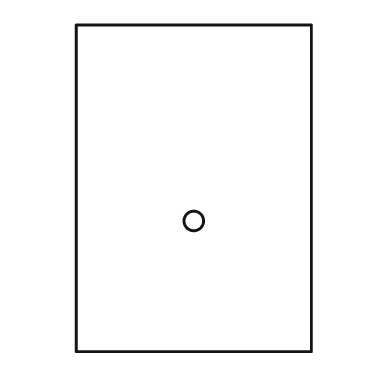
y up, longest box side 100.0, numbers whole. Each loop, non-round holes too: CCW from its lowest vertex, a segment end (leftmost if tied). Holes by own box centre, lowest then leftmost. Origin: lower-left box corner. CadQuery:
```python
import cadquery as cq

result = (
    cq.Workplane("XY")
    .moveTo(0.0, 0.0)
    .lineTo(72.0, 0.0)
    .lineTo(72.0, 100.0)
    .lineTo(0.0, 100.0)
    .close()
    .moveTo(36.0, 40.0)
    .circle(3.0)
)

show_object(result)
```